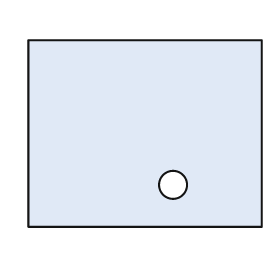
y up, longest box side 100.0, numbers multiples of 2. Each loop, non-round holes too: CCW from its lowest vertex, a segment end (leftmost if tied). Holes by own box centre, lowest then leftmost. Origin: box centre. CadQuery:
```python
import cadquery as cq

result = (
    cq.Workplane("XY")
    .moveTo(-50.0, -40.0)
    .lineTo(50.0, -40.0)
    .lineTo(50.0, 40.0)
    .lineTo(-50.0, 40.0)
    .close()
    .moveTo(12.0, -22.0)
    .circle(6.0)
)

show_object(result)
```